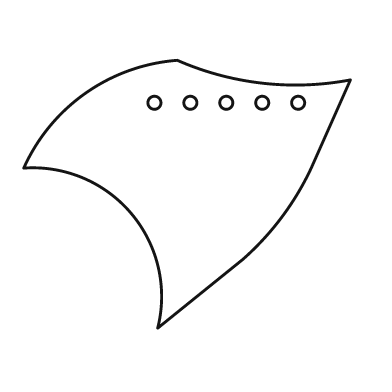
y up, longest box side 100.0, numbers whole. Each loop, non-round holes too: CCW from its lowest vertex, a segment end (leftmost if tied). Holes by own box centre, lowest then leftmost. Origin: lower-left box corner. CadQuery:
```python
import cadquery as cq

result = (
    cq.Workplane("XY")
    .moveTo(41.0, 0.0)
    .lineTo(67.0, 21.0)
    .threePointArc((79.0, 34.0), (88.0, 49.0))
    .lineTo(100.0, 76.0)
    .threePointArc((73.0, 75.0), (47.0, 82.0))
    .threePointArc((19.0, 72.0), (0.0, 49.0))
    .threePointArc((33.0, 35.0), (41.0, 0.0))
    .close()
    .moveTo(40.0, 69.0)
    .circle(2.0)
    .moveTo(51.0, 69.0)
    .circle(2.0)
    .moveTo(62.0, 69.0)
    .circle(2.0)
    .moveTo(73.0, 69.0)
    .circle(2.0)
    .moveTo(84.0, 69.0)
    .circle(2.0)
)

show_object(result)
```